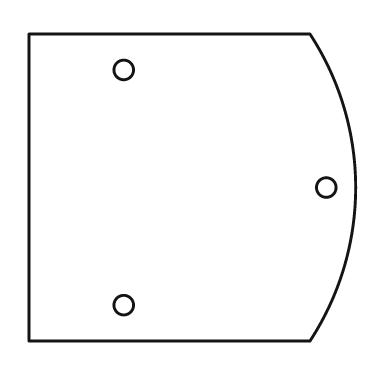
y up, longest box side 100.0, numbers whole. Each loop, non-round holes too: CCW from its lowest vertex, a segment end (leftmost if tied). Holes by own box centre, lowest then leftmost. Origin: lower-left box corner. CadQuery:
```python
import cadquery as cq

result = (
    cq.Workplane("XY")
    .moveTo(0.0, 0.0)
    .lineTo(86.0, 0.0)
    .threePointArc((100.0, 47.0), (86.0, 94.0))
    .lineTo(0.0, 94.0)
    .close()
    .moveTo(29.0, 11.0)
    .circle(3.0)
    .moveTo(91.0, 47.0)
    .circle(3.0)
    .moveTo(29.0, 83.0)
    .circle(3.0)
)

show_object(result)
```